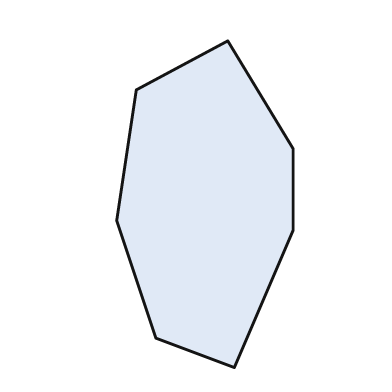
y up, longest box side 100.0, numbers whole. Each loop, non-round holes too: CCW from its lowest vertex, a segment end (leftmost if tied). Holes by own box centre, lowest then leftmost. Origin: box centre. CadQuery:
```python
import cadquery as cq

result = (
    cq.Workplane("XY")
    .moveTo(9.0, -50.0)
    .lineTo(27.0, -8.0)
    .lineTo(27.0, 17.0)
    .lineTo(7.0, 50.0)
    .lineTo(-21.0, 35.0)
    .lineTo(-27.0, -5.0)
    .lineTo(-15.0, -41.0)
    .close()
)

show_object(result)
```